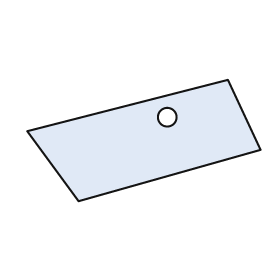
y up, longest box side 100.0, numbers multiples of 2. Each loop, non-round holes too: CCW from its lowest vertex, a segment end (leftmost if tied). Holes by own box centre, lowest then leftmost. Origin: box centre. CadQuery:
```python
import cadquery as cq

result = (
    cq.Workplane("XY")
    .moveTo(-28.0, -26.0)
    .lineTo(50.0, -4.0)
    .lineTo(36.0, 26.0)
    .lineTo(-50.0, 4.0)
    .close()
    .moveTo(10.0, 10.0)
    .circle(4.0)
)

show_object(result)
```